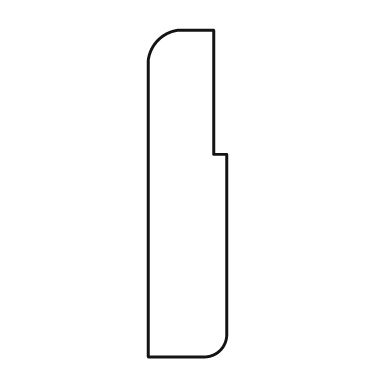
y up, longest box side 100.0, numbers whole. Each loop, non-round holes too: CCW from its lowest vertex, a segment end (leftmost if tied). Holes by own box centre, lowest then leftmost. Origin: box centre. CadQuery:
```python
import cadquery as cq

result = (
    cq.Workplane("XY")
    .moveTo(-12.0, -50.0)
    .lineTo(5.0, -50.0)
    .threePointArc((10.0, -48.0), (12.0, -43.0))
    .lineTo(12.0, 12.0)
    .lineTo(8.0, 12.0)
    .lineTo(8.0, 50.0)
    .lineTo(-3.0, 50.0)
    .threePointArc((-9.0, 47.0), (-12.0, 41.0))
    .close()
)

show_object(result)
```